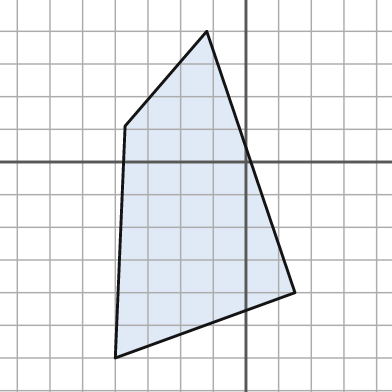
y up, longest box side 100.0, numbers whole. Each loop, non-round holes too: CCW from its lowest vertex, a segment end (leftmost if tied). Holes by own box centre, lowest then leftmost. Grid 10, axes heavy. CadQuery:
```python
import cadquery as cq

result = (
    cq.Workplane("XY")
    .moveTo(-40.0, -60.0)
    .lineTo(15.0, -40.0)
    .lineTo(-12.0, 40.0)
    .lineTo(-37.0, 11.0)
    .close()
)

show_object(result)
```